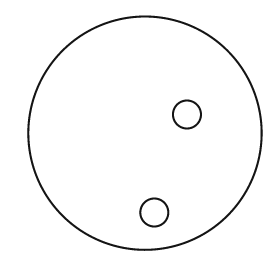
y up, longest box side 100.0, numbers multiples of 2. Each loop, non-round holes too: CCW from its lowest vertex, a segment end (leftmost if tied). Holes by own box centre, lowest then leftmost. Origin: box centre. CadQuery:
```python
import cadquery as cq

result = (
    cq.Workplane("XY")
    .moveTo(0.0, 0.0)
    .circle(50.0)
    .moveTo(4.0, -34.0)
    .circle(6.0)
    .moveTo(18.0, 8.0)
    .circle(6.0)
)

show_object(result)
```